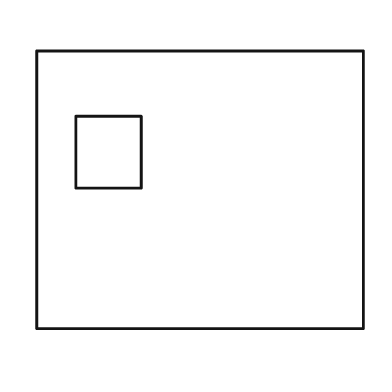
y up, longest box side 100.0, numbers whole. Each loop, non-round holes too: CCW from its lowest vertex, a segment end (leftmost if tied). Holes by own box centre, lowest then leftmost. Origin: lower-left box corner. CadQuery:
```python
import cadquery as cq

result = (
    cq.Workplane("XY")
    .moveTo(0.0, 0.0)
    .lineTo(100.0, 0.0)
    .lineTo(100.0, 85.0)
    .lineTo(0.0, 85.0)
    .close()
    .moveTo(12.0, 43.0)
    .lineTo(32.0, 43.0)
    .lineTo(32.0, 65.0)
    .lineTo(12.0, 65.0)
    .close()
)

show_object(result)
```